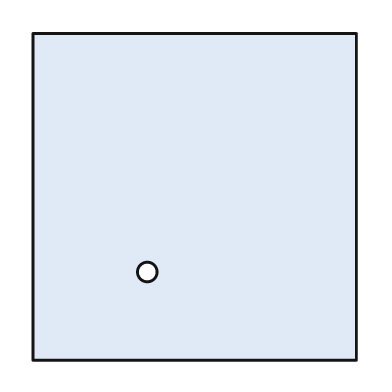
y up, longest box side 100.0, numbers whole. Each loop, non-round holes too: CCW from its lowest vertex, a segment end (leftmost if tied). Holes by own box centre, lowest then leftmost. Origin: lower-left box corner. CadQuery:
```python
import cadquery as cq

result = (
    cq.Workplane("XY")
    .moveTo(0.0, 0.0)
    .lineTo(99.0, 0.0)
    .lineTo(99.0, 100.0)
    .lineTo(0.0, 100.0)
    .close()
    .moveTo(35.0, 27.0)
    .circle(3.0)
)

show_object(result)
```